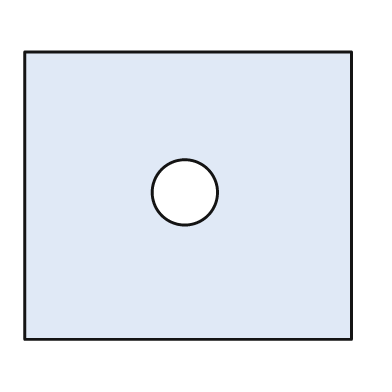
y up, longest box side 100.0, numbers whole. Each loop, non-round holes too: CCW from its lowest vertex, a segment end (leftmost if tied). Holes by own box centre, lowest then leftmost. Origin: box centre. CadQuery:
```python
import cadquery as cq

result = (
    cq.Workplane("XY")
    .moveTo(-50.0, -44.0)
    .lineTo(50.0, -44.0)
    .lineTo(50.0, 44.0)
    .lineTo(-50.0, 44.0)
    .close()
    .moveTo(-1.0, 1.0)
    .circle(10.0)
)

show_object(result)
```